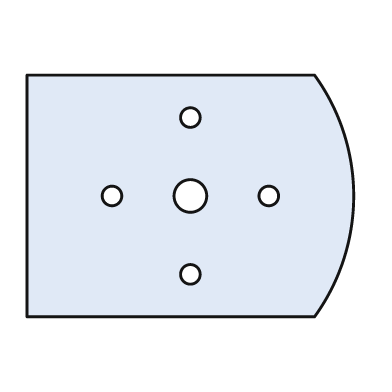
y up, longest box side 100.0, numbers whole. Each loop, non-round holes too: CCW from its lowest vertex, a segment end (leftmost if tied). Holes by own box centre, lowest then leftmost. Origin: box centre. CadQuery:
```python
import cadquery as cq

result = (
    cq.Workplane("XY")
    .moveTo(-50.0, -37.0)
    .lineTo(38.0, -37.0)
    .threePointArc((50.0, 0.0), (38.0, 37.0))
    .lineTo(-50.0, 37.0)
    .close()
    .moveTo(0.0, -24.0)
    .circle(3.0)
    .moveTo(-24.0, 0.0)
    .circle(3.0)
    .moveTo(0.0, 0.0)
    .circle(5.0)
    .moveTo(24.0, 0.0)
    .circle(3.0)
    .moveTo(0.0, 24.0)
    .circle(3.0)
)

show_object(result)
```